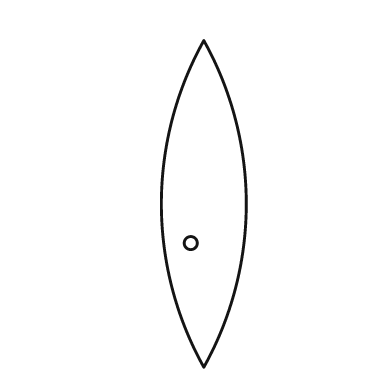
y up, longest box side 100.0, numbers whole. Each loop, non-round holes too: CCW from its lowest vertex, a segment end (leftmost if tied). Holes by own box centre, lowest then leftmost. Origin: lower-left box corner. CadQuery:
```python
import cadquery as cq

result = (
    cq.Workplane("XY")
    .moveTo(13.0, 0.0)
    .threePointArc((26.0, 50.0), (13.0, 100.0))
    .threePointArc((0.0, 50.0), (13.0, 0.0))
    .close()
    .moveTo(9.0, 38.0)
    .circle(2.0)
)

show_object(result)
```